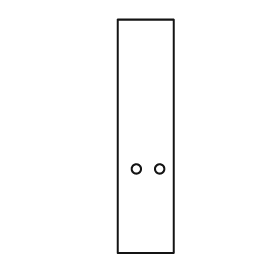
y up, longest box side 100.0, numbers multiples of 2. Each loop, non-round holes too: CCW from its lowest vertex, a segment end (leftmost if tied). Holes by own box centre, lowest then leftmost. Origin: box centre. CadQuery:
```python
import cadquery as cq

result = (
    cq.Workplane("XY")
    .moveTo(-12.0, -50.0)
    .lineTo(12.0, -50.0)
    .lineTo(12.0, 50.0)
    .lineTo(-12.0, 50.0)
    .close()
    .moveTo(-4.0, -14.0)
    .circle(2.0)
    .moveTo(6.0, -14.0)
    .circle(2.0)
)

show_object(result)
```